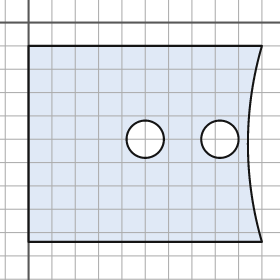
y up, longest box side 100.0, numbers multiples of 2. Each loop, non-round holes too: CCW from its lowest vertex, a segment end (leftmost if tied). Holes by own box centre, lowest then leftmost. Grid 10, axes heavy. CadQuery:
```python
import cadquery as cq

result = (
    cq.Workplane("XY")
    .moveTo(0.0, -94.0)
    .lineTo(100.0, -94.0)
    .threePointArc((94.0, -52.0), (100.0, -10.0))
    .lineTo(0.0, -10.0)
    .close()
    .moveTo(50.0, -50.0)
    .circle(8.0)
    .moveTo(82.0, -50.0)
    .circle(8.0)
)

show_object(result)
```